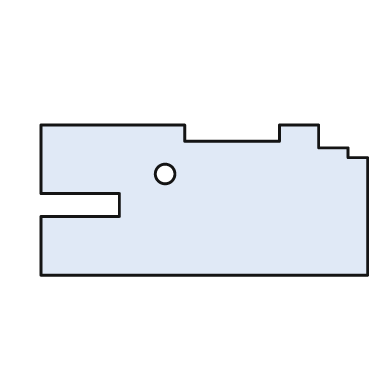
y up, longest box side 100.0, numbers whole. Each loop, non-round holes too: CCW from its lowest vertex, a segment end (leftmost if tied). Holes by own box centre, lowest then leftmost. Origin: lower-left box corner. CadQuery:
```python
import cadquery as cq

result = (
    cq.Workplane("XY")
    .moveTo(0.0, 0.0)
    .lineTo(100.0, 0.0)
    .lineTo(100.0, 36.0)
    .lineTo(94.0, 36.0)
    .lineTo(94.0, 39.0)
    .lineTo(85.0, 39.0)
    .lineTo(85.0, 46.0)
    .lineTo(73.0, 46.0)
    .lineTo(73.0, 41.0)
    .lineTo(44.0, 41.0)
    .lineTo(44.0, 46.0)
    .lineTo(0.0, 46.0)
    .lineTo(0.0, 25.0)
    .lineTo(24.0, 25.0)
    .lineTo(24.0, 18.0)
    .lineTo(0.0, 18.0)
    .close()
    .moveTo(38.0, 31.0)
    .circle(3.0)
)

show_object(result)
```